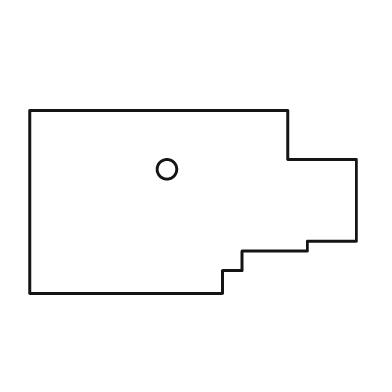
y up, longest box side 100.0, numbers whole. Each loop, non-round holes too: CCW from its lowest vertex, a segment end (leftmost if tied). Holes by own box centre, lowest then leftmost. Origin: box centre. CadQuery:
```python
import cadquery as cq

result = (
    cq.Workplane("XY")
    .moveTo(-50.0, -28.0)
    .lineTo(9.0, -28.0)
    .lineTo(9.0, -21.0)
    .lineTo(15.0, -21.0)
    .lineTo(15.0, -15.0)
    .lineTo(35.0, -15.0)
    .lineTo(35.0, -12.0)
    .lineTo(50.0, -12.0)
    .lineTo(50.0, 13.0)
    .lineTo(29.0, 13.0)
    .lineTo(29.0, 28.0)
    .lineTo(-50.0, 28.0)
    .close()
    .moveTo(-8.0, 10.0)
    .circle(3.0)
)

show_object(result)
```